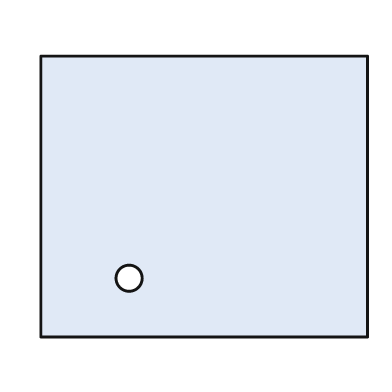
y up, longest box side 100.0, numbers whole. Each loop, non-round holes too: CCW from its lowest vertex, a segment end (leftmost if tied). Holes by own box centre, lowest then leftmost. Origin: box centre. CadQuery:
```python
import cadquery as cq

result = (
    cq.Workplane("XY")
    .moveTo(-50.0, -43.0)
    .lineTo(50.0, -43.0)
    .lineTo(50.0, 43.0)
    .lineTo(-50.0, 43.0)
    .close()
    .moveTo(-23.0, -25.0)
    .circle(4.0)
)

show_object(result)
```